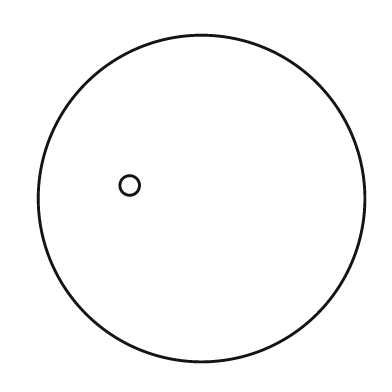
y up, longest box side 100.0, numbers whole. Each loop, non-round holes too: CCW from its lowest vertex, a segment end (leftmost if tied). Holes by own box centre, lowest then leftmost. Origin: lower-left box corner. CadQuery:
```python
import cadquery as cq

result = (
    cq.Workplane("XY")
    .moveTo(50.0, 50.0)
    .circle(50.0)
    .moveTo(28.0, 54.0)
    .circle(3.0)
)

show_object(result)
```